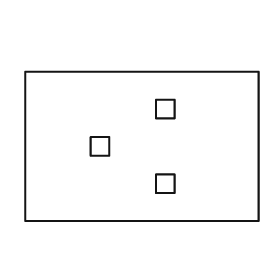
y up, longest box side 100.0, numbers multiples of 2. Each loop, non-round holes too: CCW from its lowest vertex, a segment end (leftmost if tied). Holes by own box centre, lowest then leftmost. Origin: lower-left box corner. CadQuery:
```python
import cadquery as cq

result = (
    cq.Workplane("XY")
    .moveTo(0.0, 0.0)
    .lineTo(100.0, 0.0)
    .lineTo(100.0, 64.0)
    .lineTo(0.0, 64.0)
    .close()
    .moveTo(56.0, 12.0)
    .lineTo(64.0, 12.0)
    .lineTo(64.0, 20.0)
    .lineTo(56.0, 20.0)
    .close()
    .moveTo(28.0, 28.0)
    .lineTo(36.0, 28.0)
    .lineTo(36.0, 36.0)
    .lineTo(28.0, 36.0)
    .close()
    .moveTo(56.0, 44.0)
    .lineTo(64.0, 44.0)
    .lineTo(64.0, 52.0)
    .lineTo(56.0, 52.0)
    .close()
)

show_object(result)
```